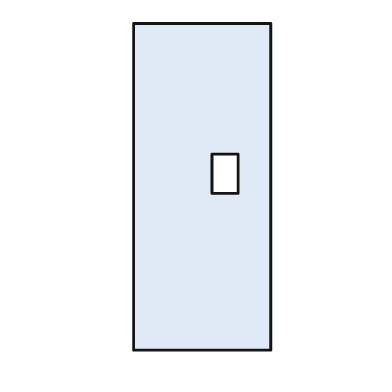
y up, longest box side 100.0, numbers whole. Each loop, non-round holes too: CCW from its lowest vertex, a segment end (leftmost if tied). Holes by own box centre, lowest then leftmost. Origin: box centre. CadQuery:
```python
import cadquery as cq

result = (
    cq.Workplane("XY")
    .moveTo(-21.0, -50.0)
    .lineTo(21.0, -50.0)
    .lineTo(21.0, 50.0)
    .lineTo(-21.0, 50.0)
    .close()
    .moveTo(3.0, -2.0)
    .lineTo(11.0, -2.0)
    .lineTo(11.0, 10.0)
    .lineTo(3.0, 10.0)
    .close()
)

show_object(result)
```